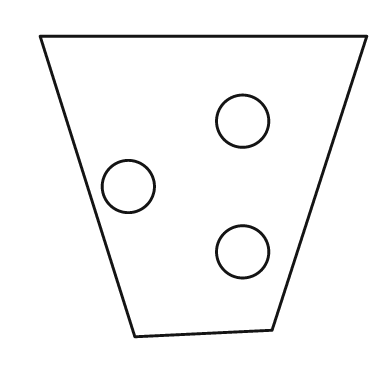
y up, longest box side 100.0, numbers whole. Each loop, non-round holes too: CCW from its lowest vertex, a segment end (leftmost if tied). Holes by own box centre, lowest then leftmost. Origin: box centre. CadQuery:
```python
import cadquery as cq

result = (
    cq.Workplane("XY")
    .moveTo(-21.0, -46.0)
    .lineTo(21.0, -44.0)
    .lineTo(50.0, 46.0)
    .lineTo(-50.0, 46.0)
    .close()
    .moveTo(12.0, -20.0)
    .circle(8.0)
    .moveTo(-23.0, 0.0)
    .circle(8.0)
    .moveTo(12.0, 20.0)
    .circle(8.0)
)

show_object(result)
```